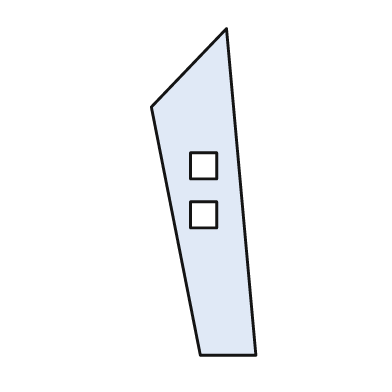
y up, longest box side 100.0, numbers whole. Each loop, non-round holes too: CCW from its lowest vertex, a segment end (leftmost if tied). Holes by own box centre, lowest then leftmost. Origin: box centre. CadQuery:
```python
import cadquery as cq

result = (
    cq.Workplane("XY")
    .moveTo(-1.0, -50.0)
    .lineTo(16.0, -50.0)
    .lineTo(7.0, 50.0)
    .lineTo(-16.0, 26.0)
    .close()
    .moveTo(-4.0, -11.0)
    .lineTo(4.0, -11.0)
    .lineTo(4.0, -3.0)
    .lineTo(-4.0, -3.0)
    .close()
    .moveTo(-4.0, 4.0)
    .lineTo(4.0, 4.0)
    .lineTo(4.0, 12.0)
    .lineTo(-4.0, 12.0)
    .close()
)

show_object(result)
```